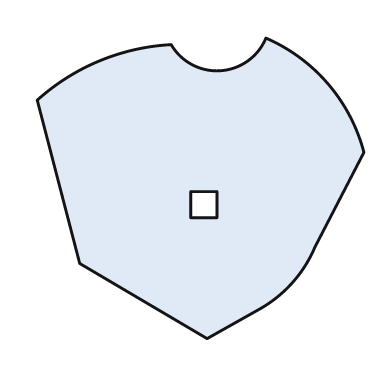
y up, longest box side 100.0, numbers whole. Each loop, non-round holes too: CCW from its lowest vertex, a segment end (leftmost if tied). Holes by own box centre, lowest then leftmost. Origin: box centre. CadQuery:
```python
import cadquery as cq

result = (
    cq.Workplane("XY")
    .moveTo(2.0, -46.0)
    .lineTo(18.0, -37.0)
    .threePointArc((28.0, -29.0), (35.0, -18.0))
    .lineTo(50.0, 11.0)
    .threePointArc((39.0, 32.0), (20.0, 46.0))
    .threePointArc((6.0, 36.0), (-9.0, 44.0))
    .threePointArc((-31.0, 39.0), (-50.0, 27.0))
    .lineTo(-37.0, -23.0)
    .close()
    .moveTo(-3.0, -9.0)
    .lineTo(5.0, -9.0)
    .lineTo(5.0, -1.0)
    .lineTo(-3.0, -1.0)
    .close()
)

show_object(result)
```